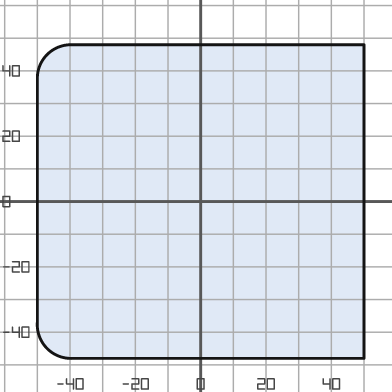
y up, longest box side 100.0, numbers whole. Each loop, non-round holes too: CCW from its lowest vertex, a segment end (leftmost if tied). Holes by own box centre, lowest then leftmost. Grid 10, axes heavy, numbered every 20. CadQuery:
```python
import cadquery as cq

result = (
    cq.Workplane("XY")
    .moveTo(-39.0, -48.0)
    .lineTo(50.0, -48.0)
    .lineTo(50.0, 48.0)
    .lineTo(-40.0, 48.0)
    .threePointArc((-47.0, 45.0), (-50.0, 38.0))
    .lineTo(-50.0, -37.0)
    .threePointArc((-47.0, -45.0), (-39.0, -48.0))
    .close()
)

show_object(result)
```